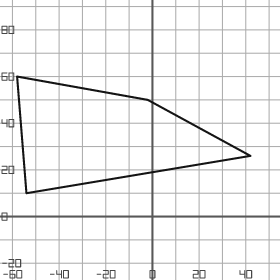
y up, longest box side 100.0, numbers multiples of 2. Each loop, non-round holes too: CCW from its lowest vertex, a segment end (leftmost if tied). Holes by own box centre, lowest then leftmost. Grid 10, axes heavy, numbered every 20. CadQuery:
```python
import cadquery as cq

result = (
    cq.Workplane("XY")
    .moveTo(-54.0, 10.0)
    .lineTo(42.0, 26.0)
    .lineTo(-2.0, 50.0)
    .lineTo(-58.0, 60.0)
    .close()
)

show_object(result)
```